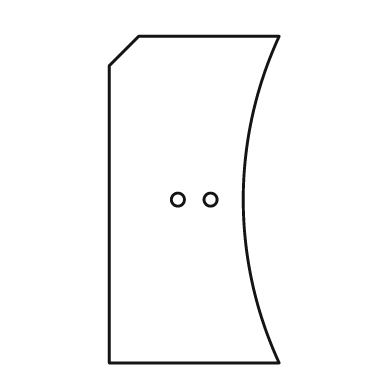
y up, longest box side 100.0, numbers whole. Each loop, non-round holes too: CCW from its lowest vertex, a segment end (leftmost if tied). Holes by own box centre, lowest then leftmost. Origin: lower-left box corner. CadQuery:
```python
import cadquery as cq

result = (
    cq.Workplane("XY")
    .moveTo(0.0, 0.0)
    .lineTo(52.0, 0.0)
    .threePointArc((41.0, 50.0), (52.0, 100.0))
    .lineTo(9.0, 100.0)
    .lineTo(0.0, 91.0)
    .close()
    .moveTo(21.0, 50.0)
    .circle(2.0)
    .moveTo(31.0, 50.0)
    .circle(2.0)
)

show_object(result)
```